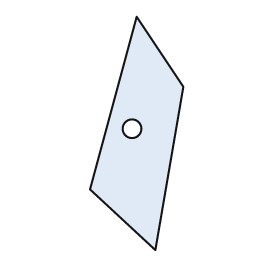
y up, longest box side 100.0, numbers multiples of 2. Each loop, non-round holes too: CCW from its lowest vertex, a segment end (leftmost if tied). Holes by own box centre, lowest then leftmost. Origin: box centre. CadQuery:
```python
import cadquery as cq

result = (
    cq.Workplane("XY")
    .moveTo(8.0, -50.0)
    .lineTo(20.0, 20.0)
    .lineTo(0.0, 50.0)
    .lineTo(-20.0, -24.0)
    .close()
    .moveTo(-2.0, 2.0)
    .circle(4.0)
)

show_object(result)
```